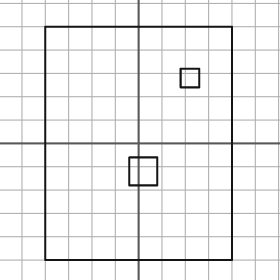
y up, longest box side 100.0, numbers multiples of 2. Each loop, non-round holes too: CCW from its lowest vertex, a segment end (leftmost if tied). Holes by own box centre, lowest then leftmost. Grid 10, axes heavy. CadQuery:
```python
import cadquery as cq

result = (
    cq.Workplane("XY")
    .moveTo(-40.0, -50.0)
    .lineTo(40.0, -50.0)
    .lineTo(40.0, 50.0)
    .lineTo(-40.0, 50.0)
    .close()
    .moveTo(-4.0, -18.0)
    .lineTo(8.0, -18.0)
    .lineTo(8.0, -6.0)
    .lineTo(-4.0, -6.0)
    .close()
    .moveTo(18.0, 24.0)
    .lineTo(26.0, 24.0)
    .lineTo(26.0, 32.0)
    .lineTo(18.0, 32.0)
    .close()
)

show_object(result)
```